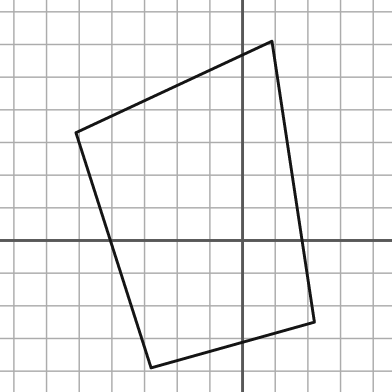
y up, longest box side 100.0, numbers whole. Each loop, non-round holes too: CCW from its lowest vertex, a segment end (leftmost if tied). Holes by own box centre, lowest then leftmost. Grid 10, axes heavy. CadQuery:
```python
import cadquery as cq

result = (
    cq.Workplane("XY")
    .moveTo(-28.0, -39.0)
    .lineTo(22.0, -25.0)
    .lineTo(9.0, 61.0)
    .lineTo(-51.0, 33.0)
    .close()
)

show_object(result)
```